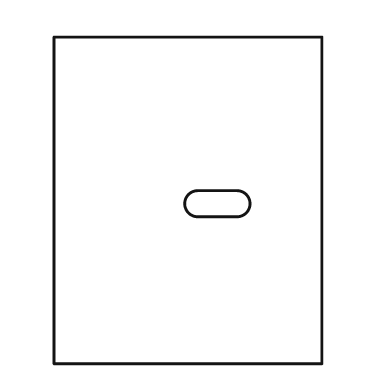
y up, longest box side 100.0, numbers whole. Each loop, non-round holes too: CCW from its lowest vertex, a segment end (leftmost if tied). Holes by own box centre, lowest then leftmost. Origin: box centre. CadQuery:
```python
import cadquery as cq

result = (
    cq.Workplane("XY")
    .moveTo(-41.0, -50.0)
    .lineTo(41.0, -50.0)
    .lineTo(41.0, 50.0)
    .lineTo(-41.0, 50.0)
    .close()
    .moveTo(3.0, -5.0)
    .lineTo(15.0, -5.0)
    .threePointArc((19.0, -1.0), (15.0, 3.0))
    .lineTo(3.0, 3.0)
    .threePointArc((-1.0, -1.0), (3.0, -5.0))
    .close()
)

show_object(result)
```